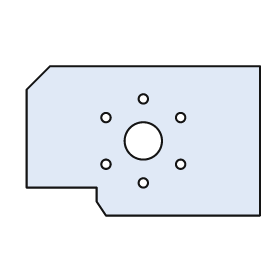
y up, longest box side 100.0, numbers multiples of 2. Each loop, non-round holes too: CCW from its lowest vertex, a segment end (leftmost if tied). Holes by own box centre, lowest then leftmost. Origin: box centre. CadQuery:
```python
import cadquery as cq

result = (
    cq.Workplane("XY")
    .moveTo(-16.0, -32.0)
    .lineTo(50.0, -32.0)
    .lineTo(50.0, 32.0)
    .lineTo(-40.0, 32.0)
    .lineTo(-50.0, 22.0)
    .lineTo(-50.0, -20.0)
    .lineTo(-20.0, -20.0)
    .lineTo(-20.0, -26.0)
    .close()
    .moveTo(0.0, -18.0)
    .circle(2.0)
    .moveTo(-16.0, -10.0)
    .circle(2.0)
    .moveTo(16.0, -10.0)
    .circle(2.0)
    .moveTo(0.0, 0.0)
    .circle(8.0)
    .moveTo(-16.0, 10.0)
    .circle(2.0)
    .moveTo(16.0, 10.0)
    .circle(2.0)
    .moveTo(0.0, 18.0)
    .circle(2.0)
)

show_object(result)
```